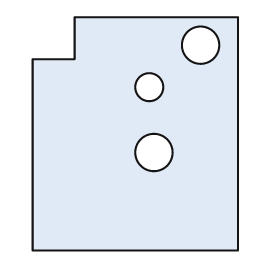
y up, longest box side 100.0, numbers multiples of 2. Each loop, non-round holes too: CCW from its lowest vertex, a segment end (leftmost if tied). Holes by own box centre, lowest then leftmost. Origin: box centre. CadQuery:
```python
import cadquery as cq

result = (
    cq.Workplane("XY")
    .moveTo(-44.0, -50.0)
    .lineTo(44.0, -50.0)
    .lineTo(44.0, 50.0)
    .lineTo(-26.0, 50.0)
    .lineTo(-26.0, 32.0)
    .lineTo(-44.0, 32.0)
    .close()
    .moveTo(8.0, -8.0)
    .circle(8.0)
    .moveTo(6.0, 20.0)
    .circle(6.0)
    .moveTo(28.0, 38.0)
    .circle(8.0)
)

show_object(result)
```